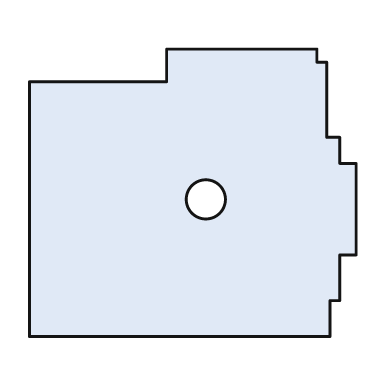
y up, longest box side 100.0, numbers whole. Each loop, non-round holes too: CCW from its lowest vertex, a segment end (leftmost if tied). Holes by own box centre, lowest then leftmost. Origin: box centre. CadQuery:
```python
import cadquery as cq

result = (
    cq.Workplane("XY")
    .moveTo(-50.0, -44.0)
    .lineTo(42.0, -44.0)
    .lineTo(42.0, -33.0)
    .lineTo(45.0, -33.0)
    .lineTo(45.0, -19.0)
    .lineTo(50.0, -19.0)
    .lineTo(50.0, 9.0)
    .lineTo(45.0, 9.0)
    .lineTo(45.0, 17.0)
    .lineTo(41.0, 17.0)
    .lineTo(41.0, 40.0)
    .lineTo(38.0, 40.0)
    .lineTo(38.0, 44.0)
    .lineTo(-8.0, 44.0)
    .lineTo(-8.0, 34.0)
    .lineTo(-50.0, 34.0)
    .close()
    .moveTo(4.0, -2.0)
    .circle(6.0)
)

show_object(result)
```